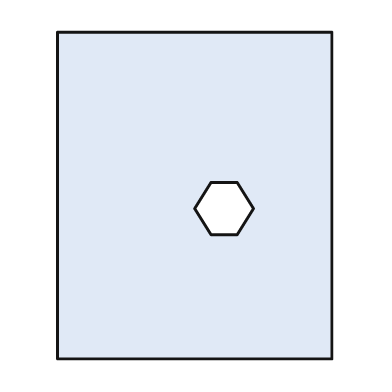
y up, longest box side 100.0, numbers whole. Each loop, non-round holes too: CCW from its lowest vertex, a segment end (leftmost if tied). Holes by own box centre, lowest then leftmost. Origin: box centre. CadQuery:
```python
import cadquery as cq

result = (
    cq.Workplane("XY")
    .moveTo(-42.0, -50.0)
    .lineTo(42.0, -50.0)
    .lineTo(42.0, 50.0)
    .lineTo(-42.0, 50.0)
    .close()
    .moveTo(5.0, -12.0)
    .lineTo(13.0, -12.0)
    .lineTo(18.0, -4.0)
    .lineTo(13.0, 4.0)
    .lineTo(5.0, 4.0)
    .lineTo(0.0, -4.0)
    .close()
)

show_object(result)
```